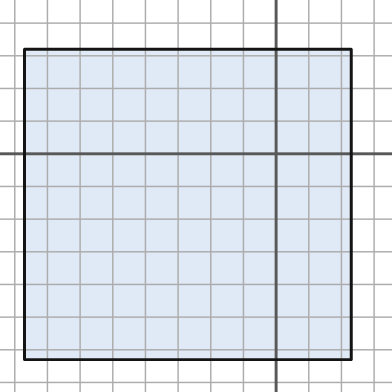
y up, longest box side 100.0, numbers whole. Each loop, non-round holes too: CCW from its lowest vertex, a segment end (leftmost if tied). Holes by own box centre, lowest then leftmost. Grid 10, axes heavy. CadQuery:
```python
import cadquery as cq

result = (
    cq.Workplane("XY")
    .moveTo(-77.0, -63.0)
    .lineTo(23.0, -63.0)
    .lineTo(23.0, 32.0)
    .lineTo(-77.0, 32.0)
    .close()
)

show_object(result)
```